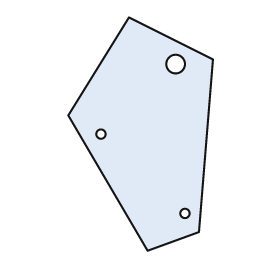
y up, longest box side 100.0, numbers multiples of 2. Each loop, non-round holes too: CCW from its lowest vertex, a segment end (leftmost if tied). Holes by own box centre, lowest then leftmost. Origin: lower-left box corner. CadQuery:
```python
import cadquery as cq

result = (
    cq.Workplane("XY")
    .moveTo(34.0, 0.0)
    .lineTo(56.0, 8.0)
    .lineTo(62.0, 82.0)
    .lineTo(26.0, 100.0)
    .lineTo(0.0, 58.0)
    .close()
    .moveTo(50.0, 16.0)
    .circle(2.0)
    .moveTo(14.0, 50.0)
    .circle(2.0)
    .moveTo(46.0, 80.0)
    .circle(4.0)
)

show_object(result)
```